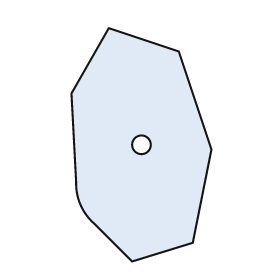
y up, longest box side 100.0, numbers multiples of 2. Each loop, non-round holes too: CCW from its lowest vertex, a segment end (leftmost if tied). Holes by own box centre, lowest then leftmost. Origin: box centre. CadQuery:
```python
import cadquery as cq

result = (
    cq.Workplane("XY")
    .moveTo(-4.0, -50.0)
    .lineTo(22.0, -42.0)
    .lineTo(30.0, -2.0)
    .lineTo(16.0, 40.0)
    .lineTo(-14.0, 50.0)
    .lineTo(-30.0, 22.0)
    .lineTo(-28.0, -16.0)
    .threePointArc((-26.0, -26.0), (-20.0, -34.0))
    .close()
    .moveTo(0.0, 0.0)
    .circle(4.0)
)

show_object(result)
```